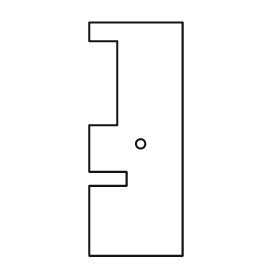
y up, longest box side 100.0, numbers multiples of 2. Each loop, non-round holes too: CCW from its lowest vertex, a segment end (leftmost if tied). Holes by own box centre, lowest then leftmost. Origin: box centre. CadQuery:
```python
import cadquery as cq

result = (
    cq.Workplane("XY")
    .moveTo(-20.0, -50.0)
    .lineTo(20.0, -50.0)
    .lineTo(20.0, 50.0)
    .lineTo(-20.0, 50.0)
    .lineTo(-20.0, 42.0)
    .lineTo(-8.0, 42.0)
    .lineTo(-8.0, 6.0)
    .lineTo(-20.0, 6.0)
    .lineTo(-20.0, -14.0)
    .lineTo(-4.0, -14.0)
    .lineTo(-4.0, -20.0)
    .lineTo(-20.0, -20.0)
    .close()
    .moveTo(2.0, -2.0)
    .circle(2.0)
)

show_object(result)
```